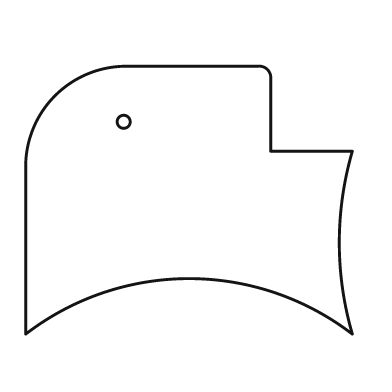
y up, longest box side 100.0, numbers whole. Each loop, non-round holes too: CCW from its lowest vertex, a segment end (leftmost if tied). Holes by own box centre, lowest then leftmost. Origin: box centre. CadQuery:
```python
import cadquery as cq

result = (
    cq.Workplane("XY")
    .moveTo(-50.0, -41.0)
    .threePointArc((0.0, -24.0), (50.0, -41.0))
    .threePointArc((46.0, -13.0), (50.0, 15.0))
    .lineTo(25.0, 15.0)
    .lineTo(25.0, 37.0)
    .threePointArc((24.0, 40.0), (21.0, 41.0))
    .lineTo(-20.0, 41.0)
    .threePointArc((-41.0, 32.0), (-50.0, 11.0))
    .close()
    .moveTo(-20.0, 24.0)
    .circle(2.0)
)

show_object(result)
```